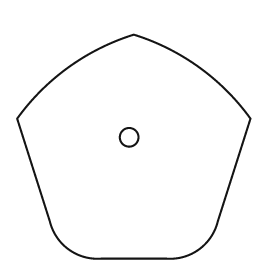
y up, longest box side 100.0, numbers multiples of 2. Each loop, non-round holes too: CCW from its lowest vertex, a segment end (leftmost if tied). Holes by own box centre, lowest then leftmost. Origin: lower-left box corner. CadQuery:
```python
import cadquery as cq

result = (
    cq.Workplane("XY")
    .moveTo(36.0, 0.0)
    .lineTo(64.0, 0.0)
    .threePointArc((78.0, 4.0), (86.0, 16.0))
    .lineTo(100.0, 60.0)
    .threePointArc((78.0, 82.0), (50.0, 96.0))
    .threePointArc((22.0, 82.0), (0.0, 60.0))
    .lineTo(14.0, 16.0)
    .threePointArc((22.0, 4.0), (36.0, 0.0))
    .close()
    .moveTo(48.0, 52.0)
    .circle(4.0)
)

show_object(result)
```